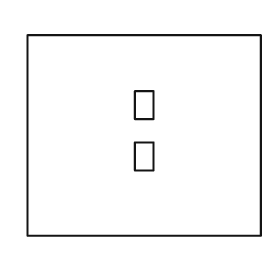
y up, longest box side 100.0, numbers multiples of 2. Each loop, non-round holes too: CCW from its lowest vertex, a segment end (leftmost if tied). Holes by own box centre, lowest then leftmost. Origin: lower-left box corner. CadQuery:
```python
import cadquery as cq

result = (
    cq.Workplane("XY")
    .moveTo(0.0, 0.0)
    .lineTo(100.0, 0.0)
    .lineTo(100.0, 86.0)
    .lineTo(0.0, 86.0)
    .close()
    .moveTo(46.0, 28.0)
    .lineTo(54.0, 28.0)
    .lineTo(54.0, 40.0)
    .lineTo(46.0, 40.0)
    .close()
    .moveTo(46.0, 50.0)
    .lineTo(54.0, 50.0)
    .lineTo(54.0, 62.0)
    .lineTo(46.0, 62.0)
    .close()
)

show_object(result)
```